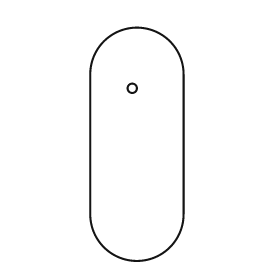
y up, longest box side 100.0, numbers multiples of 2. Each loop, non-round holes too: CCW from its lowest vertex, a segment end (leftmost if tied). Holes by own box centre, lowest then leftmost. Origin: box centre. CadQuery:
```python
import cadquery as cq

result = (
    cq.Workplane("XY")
    .moveTo(-20.0, -30.0)
    .threePointArc((0.0, -50.0), (20.0, -30.0))
    .lineTo(20.0, 30.0)
    .threePointArc((0.0, 50.0), (-20.0, 30.0))
    .close()
    .moveTo(-2.0, 24.0)
    .circle(2.0)
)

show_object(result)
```